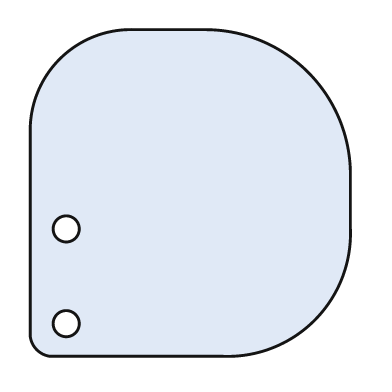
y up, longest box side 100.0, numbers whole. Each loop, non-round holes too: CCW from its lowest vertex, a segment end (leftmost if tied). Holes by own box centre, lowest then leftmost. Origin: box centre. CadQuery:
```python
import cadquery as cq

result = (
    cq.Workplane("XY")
    .moveTo(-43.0, -50.0)
    .lineTo(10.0, -50.0)
    .threePointArc((38.0, -39.0), (49.0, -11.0))
    .lineTo(49.0, 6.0)
    .threePointArc((36.0, 37.0), (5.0, 50.0))
    .lineTo(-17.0, 50.0)
    .threePointArc((-40.0, 41.0), (-49.0, 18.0))
    .lineTo(-49.0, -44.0)
    .threePointArc((-47.0, -48.0), (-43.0, -50.0))
    .close()
    .moveTo(-38.0, -40.0)
    .circle(4.0)
    .moveTo(-38.0, -11.0)
    .circle(4.0)
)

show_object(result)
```